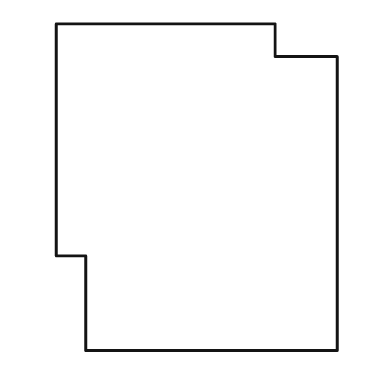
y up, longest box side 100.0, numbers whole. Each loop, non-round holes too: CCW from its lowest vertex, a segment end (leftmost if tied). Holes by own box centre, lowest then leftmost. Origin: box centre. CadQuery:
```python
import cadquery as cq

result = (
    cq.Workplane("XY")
    .moveTo(-34.0, -50.0)
    .lineTo(43.0, -50.0)
    .lineTo(43.0, 40.0)
    .lineTo(24.0, 40.0)
    .lineTo(24.0, 50.0)
    .lineTo(-43.0, 50.0)
    .lineTo(-43.0, -21.0)
    .lineTo(-34.0, -21.0)
    .close()
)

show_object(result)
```